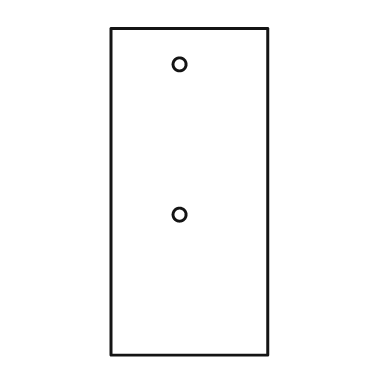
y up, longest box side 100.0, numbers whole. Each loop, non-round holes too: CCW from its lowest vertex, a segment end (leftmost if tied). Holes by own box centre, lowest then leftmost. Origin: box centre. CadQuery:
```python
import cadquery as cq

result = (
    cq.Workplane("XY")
    .moveTo(-24.0, -50.0)
    .lineTo(24.0, -50.0)
    .lineTo(24.0, 50.0)
    .lineTo(-24.0, 50.0)
    .close()
    .moveTo(-3.0, -7.0)
    .circle(2.0)
    .moveTo(-3.0, 39.0)
    .circle(2.0)
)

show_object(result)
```